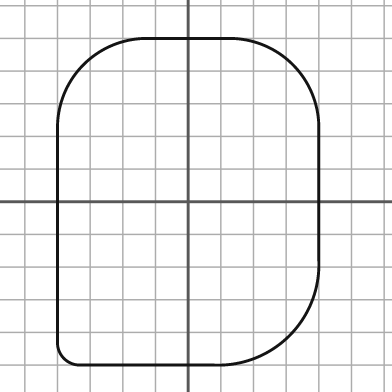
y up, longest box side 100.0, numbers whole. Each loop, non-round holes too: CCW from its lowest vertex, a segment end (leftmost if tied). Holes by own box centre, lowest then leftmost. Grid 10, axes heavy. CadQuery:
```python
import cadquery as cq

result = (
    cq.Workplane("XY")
    .moveTo(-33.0, -50.0)
    .lineTo(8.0, -50.0)
    .threePointArc((31.0, -41.0), (40.0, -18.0))
    .lineTo(40.0, 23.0)
    .threePointArc((32.0, 42.0), (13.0, 50.0))
    .lineTo(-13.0, 50.0)
    .threePointArc((-32.0, 42.0), (-40.0, 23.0))
    .lineTo(-40.0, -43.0)
    .threePointArc((-38.0, -48.0), (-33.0, -50.0))
    .close()
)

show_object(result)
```